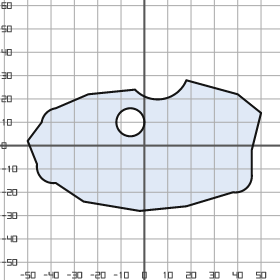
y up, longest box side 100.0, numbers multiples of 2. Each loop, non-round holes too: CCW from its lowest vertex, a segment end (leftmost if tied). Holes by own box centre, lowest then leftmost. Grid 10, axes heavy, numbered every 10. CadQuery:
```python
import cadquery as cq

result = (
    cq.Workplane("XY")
    .moveTo(-2.0, -28.0)
    .lineTo(18.0, -26.0)
    .lineTo(38.0, -20.0)
    .threePointArc((44.0, -18.0), (46.0, -12.0))
    .lineTo(46.0, -2.0)
    .lineTo(50.0, 14.0)
    .lineTo(40.0, 22.0)
    .lineTo(18.0, 28.0)
    .threePointArc((8.0, 20.0), (-4.0, 24.0))
    .lineTo(-24.0, 22.0)
    .lineTo(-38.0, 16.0)
    .threePointArc((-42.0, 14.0), (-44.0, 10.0))
    .lineTo(-50.0, 2.0)
    .lineTo(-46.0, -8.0)
    .threePointArc((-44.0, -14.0), (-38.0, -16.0))
    .lineTo(-26.0, -24.0)
    .close()
    .moveTo(-6.0, 10.0)
    .circle(6.0)
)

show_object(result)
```